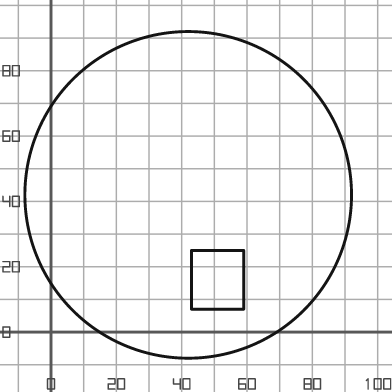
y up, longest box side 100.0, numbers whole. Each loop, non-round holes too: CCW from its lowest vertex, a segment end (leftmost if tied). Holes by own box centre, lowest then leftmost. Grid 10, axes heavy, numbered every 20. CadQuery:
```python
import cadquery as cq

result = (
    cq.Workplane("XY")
    .moveTo(42.0, 42.0)
    .circle(50.0)
    .moveTo(43.0, 7.0)
    .lineTo(59.0, 7.0)
    .lineTo(59.0, 25.0)
    .lineTo(43.0, 25.0)
    .close()
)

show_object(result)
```